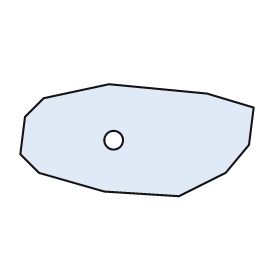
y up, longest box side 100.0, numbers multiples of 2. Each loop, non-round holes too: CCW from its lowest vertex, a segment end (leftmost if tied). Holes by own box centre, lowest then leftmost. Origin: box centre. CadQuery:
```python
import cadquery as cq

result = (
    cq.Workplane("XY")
    .moveTo(18.0, -24.0)
    .lineTo(38.0, -14.0)
    .lineTo(48.0, -2.0)
    .lineTo(50.0, 14.0)
    .lineTo(30.0, 20.0)
    .lineTo(-12.0, 24.0)
    .lineTo(-40.0, 18.0)
    .lineTo(-48.0, 10.0)
    .lineTo(-50.0, -6.0)
    .lineTo(-42.0, -14.0)
    .lineTo(-14.0, -22.0)
    .close()
    .moveTo(-10.0, 0.0)
    .circle(4.0)
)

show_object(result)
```